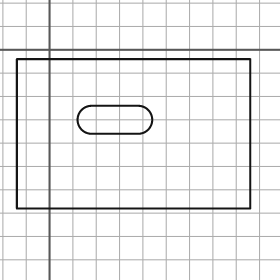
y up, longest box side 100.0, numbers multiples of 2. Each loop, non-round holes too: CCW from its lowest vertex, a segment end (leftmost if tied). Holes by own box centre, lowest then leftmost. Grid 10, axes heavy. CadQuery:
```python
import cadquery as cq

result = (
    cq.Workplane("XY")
    .moveTo(-14.0, -68.0)
    .lineTo(86.0, -68.0)
    .lineTo(86.0, -4.0)
    .lineTo(-14.0, -4.0)
    .close()
    .moveTo(18.0, -36.0)
    .lineTo(38.0, -36.0)
    .threePointArc((44.0, -30.0), (38.0, -24.0))
    .lineTo(18.0, -24.0)
    .threePointArc((12.0, -30.0), (18.0, -36.0))
    .close()
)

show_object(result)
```